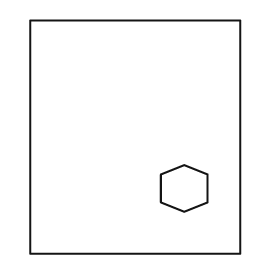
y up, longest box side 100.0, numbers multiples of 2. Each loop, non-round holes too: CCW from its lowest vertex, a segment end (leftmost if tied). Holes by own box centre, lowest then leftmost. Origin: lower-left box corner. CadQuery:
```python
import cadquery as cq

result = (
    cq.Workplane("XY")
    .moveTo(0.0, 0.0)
    .lineTo(90.0, 0.0)
    .lineTo(90.0, 100.0)
    .lineTo(0.0, 100.0)
    .close()
    .moveTo(66.0, 18.0)
    .lineTo(76.0, 22.0)
    .lineTo(76.0, 34.0)
    .lineTo(66.0, 38.0)
    .lineTo(56.0, 34.0)
    .lineTo(56.0, 22.0)
    .close()
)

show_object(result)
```